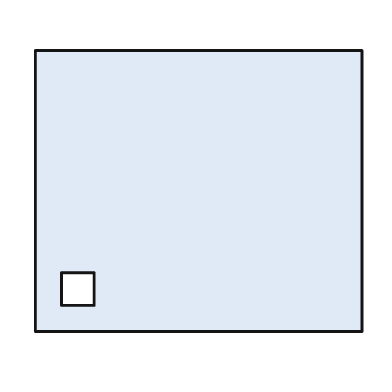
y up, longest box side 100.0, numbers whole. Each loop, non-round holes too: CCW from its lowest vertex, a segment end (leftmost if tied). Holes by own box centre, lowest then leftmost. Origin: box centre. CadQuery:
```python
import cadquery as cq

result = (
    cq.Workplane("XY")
    .moveTo(-50.0, -43.0)
    .lineTo(50.0, -43.0)
    .lineTo(50.0, 43.0)
    .lineTo(-50.0, 43.0)
    .close()
    .moveTo(-42.0, -35.0)
    .lineTo(-32.0, -35.0)
    .lineTo(-32.0, -25.0)
    .lineTo(-42.0, -25.0)
    .close()
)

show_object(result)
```